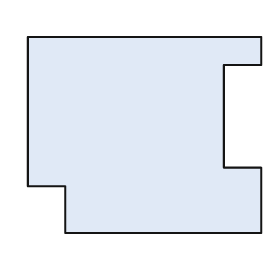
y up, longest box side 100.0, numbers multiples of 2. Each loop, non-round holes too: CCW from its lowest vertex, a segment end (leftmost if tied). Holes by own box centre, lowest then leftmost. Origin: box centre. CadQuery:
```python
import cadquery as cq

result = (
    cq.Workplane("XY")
    .moveTo(-34.0, -42.0)
    .lineTo(50.0, -42.0)
    .lineTo(50.0, -14.0)
    .lineTo(34.0, -14.0)
    .lineTo(34.0, 30.0)
    .lineTo(50.0, 30.0)
    .lineTo(50.0, 42.0)
    .lineTo(-50.0, 42.0)
    .lineTo(-50.0, -22.0)
    .lineTo(-34.0, -22.0)
    .close()
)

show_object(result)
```